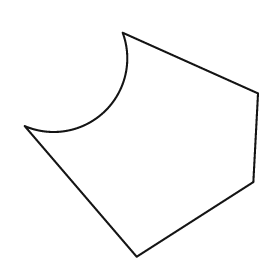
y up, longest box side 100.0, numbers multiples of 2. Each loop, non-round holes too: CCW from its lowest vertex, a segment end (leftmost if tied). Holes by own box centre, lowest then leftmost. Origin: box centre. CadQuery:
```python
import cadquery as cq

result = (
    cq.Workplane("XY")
    .moveTo(-2.0, -48.0)
    .lineTo(48.0, -16.0)
    .lineTo(50.0, 22.0)
    .lineTo(-8.0, 48.0)
    .threePointArc((-16.0, 14.0), (-50.0, 8.0))
    .close()
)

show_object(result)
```